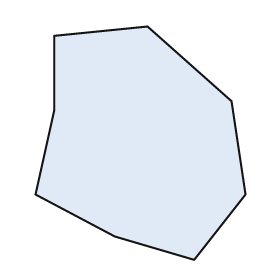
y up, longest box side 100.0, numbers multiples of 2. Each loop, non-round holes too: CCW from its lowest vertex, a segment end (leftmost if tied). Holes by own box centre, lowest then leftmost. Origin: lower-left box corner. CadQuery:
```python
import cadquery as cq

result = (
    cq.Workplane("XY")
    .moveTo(68.0, 0.0)
    .lineTo(90.0, 28.0)
    .lineTo(84.0, 68.0)
    .lineTo(48.0, 100.0)
    .lineTo(8.0, 96.0)
    .lineTo(8.0, 64.0)
    .lineTo(0.0, 28.0)
    .lineTo(34.0, 10.0)
    .close()
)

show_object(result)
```